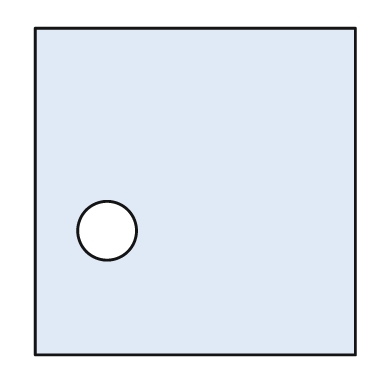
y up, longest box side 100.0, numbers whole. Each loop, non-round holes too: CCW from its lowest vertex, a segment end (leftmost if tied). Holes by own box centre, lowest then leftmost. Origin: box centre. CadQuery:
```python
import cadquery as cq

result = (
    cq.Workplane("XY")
    .moveTo(-49.0, -50.0)
    .lineTo(49.0, -50.0)
    .lineTo(49.0, 50.0)
    .lineTo(-49.0, 50.0)
    .close()
    .moveTo(-27.0, -12.0)
    .circle(9.0)
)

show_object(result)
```